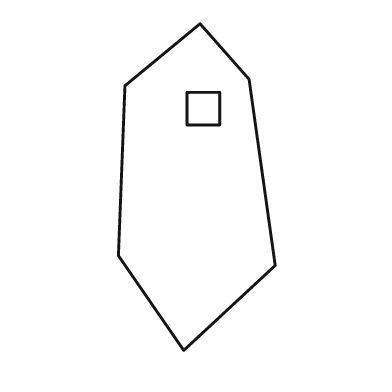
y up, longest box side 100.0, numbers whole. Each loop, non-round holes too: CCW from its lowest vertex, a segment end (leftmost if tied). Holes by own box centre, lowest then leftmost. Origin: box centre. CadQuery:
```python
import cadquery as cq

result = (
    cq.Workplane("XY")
    .moveTo(-4.0, -50.0)
    .lineTo(24.0, -24.0)
    .lineTo(16.0, 33.0)
    .lineTo(1.0, 50.0)
    .lineTo(-22.0, 31.0)
    .lineTo(-24.0, -21.0)
    .close()
    .moveTo(-3.0, 19.0)
    .lineTo(7.0, 19.0)
    .lineTo(7.0, 29.0)
    .lineTo(-3.0, 29.0)
    .close()
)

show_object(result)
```